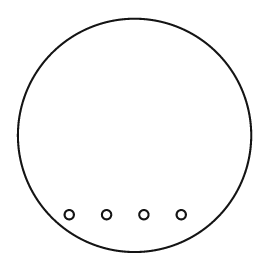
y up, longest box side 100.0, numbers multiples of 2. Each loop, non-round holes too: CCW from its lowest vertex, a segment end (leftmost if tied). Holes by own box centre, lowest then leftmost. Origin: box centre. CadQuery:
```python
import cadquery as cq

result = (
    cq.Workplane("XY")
    .moveTo(0.0, 0.0)
    .circle(50.0)
    .moveTo(-28.0, -34.0)
    .circle(2.0)
    .moveTo(-12.0, -34.0)
    .circle(2.0)
    .moveTo(4.0, -34.0)
    .circle(2.0)
    .moveTo(20.0, -34.0)
    .circle(2.0)
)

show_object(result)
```